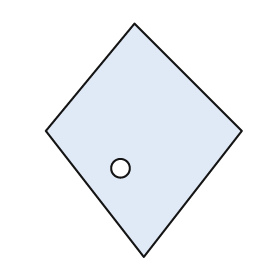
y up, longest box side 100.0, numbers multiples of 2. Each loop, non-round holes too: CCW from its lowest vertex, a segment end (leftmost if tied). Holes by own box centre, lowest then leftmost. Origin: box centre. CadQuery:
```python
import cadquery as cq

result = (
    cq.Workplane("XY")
    .moveTo(0.0, -50.0)
    .lineTo(42.0, 4.0)
    .lineTo(-4.0, 50.0)
    .lineTo(-42.0, 4.0)
    .close()
    .moveTo(-10.0, -12.0)
    .circle(4.0)
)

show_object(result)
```